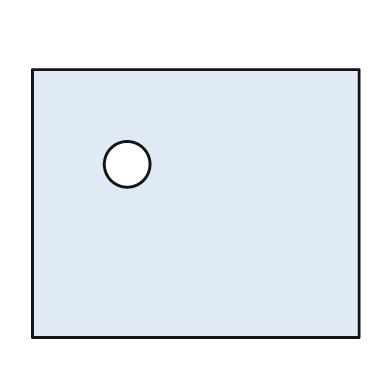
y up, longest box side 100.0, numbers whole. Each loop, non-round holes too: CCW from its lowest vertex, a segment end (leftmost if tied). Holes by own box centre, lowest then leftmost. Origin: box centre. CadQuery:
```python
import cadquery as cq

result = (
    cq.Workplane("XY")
    .moveTo(-50.0, -41.0)
    .lineTo(50.0, -41.0)
    .lineTo(50.0, 41.0)
    .lineTo(-50.0, 41.0)
    .close()
    .moveTo(-21.0, 12.0)
    .circle(7.0)
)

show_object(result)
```